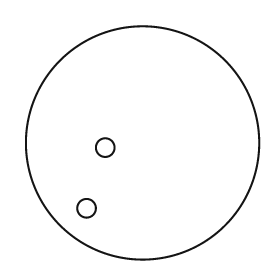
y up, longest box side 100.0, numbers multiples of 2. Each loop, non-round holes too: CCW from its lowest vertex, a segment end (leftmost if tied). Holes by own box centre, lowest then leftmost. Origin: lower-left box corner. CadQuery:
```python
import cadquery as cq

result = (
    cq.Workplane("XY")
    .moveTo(50.0, 50.0)
    .circle(50.0)
    .moveTo(26.0, 22.0)
    .circle(4.0)
    .moveTo(34.0, 48.0)
    .circle(4.0)
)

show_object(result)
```